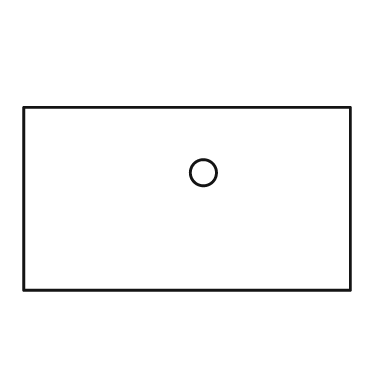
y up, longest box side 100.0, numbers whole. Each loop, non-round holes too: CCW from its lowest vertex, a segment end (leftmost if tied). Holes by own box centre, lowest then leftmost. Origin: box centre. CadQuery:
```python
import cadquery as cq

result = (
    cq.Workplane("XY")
    .moveTo(-50.0, -28.0)
    .lineTo(50.0, -28.0)
    .lineTo(50.0, 28.0)
    .lineTo(-50.0, 28.0)
    .close()
    .moveTo(5.0, 8.0)
    .circle(4.0)
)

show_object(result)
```